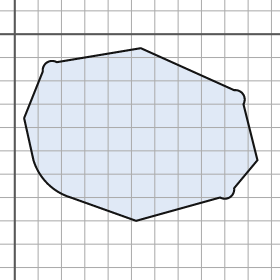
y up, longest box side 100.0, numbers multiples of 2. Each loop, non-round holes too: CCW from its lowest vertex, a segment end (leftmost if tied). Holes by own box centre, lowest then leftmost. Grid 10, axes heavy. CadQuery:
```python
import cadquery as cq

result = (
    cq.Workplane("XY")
    .moveTo(52.0, -80.0)
    .lineTo(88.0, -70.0)
    .threePointArc((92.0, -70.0), (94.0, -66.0))
    .lineTo(104.0, -54.0)
    .lineTo(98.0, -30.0)
    .threePointArc((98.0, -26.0), (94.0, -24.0))
    .lineTo(54.0, -6.0)
    .lineTo(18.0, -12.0)
    .threePointArc((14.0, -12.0), (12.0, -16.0))
    .lineTo(4.0, -36.0)
    .lineTo(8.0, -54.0)
    .threePointArc((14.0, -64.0), (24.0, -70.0))
    .close()
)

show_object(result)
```